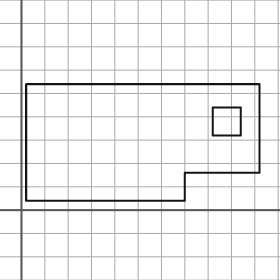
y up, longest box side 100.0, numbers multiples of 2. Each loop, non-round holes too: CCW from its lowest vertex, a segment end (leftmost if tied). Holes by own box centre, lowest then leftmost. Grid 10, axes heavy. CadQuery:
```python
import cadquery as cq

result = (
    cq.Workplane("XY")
    .moveTo(2.0, 4.0)
    .lineTo(70.0, 4.0)
    .lineTo(70.0, 16.0)
    .lineTo(102.0, 16.0)
    .lineTo(102.0, 54.0)
    .lineTo(2.0, 54.0)
    .close()
    .moveTo(82.0, 32.0)
    .lineTo(94.0, 32.0)
    .lineTo(94.0, 44.0)
    .lineTo(82.0, 44.0)
    .close()
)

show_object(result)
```